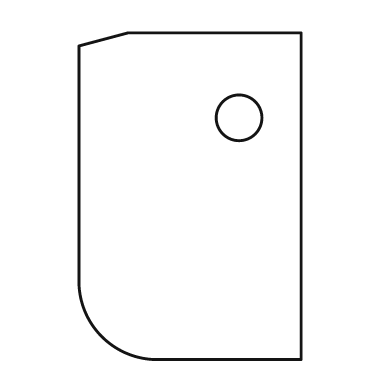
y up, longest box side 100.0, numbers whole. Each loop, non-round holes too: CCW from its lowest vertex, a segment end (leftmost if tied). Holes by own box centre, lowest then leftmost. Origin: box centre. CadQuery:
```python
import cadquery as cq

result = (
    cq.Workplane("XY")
    .moveTo(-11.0, -50.0)
    .lineTo(34.0, -50.0)
    .lineTo(34.0, 50.0)
    .lineTo(-19.0, 50.0)
    .lineTo(-34.0, 46.0)
    .lineTo(-34.0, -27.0)
    .threePointArc((-27.0, -43.0), (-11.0, -50.0))
    .close()
    .moveTo(15.0, 24.0)
    .circle(7.0)
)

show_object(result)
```